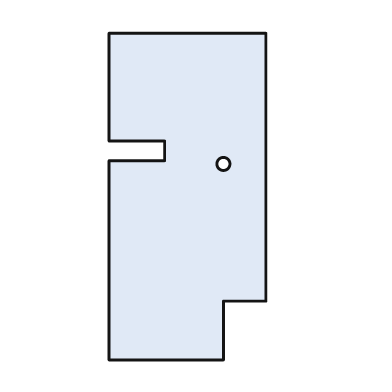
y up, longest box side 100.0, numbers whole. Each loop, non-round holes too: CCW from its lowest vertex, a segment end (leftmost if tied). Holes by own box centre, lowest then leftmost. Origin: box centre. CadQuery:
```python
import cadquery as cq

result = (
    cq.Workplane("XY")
    .moveTo(-24.0, -50.0)
    .lineTo(11.0, -50.0)
    .lineTo(11.0, -32.0)
    .lineTo(24.0, -32.0)
    .lineTo(24.0, 50.0)
    .lineTo(-24.0, 50.0)
    .lineTo(-24.0, 17.0)
    .lineTo(-7.0, 17.0)
    .lineTo(-7.0, 11.0)
    .lineTo(-24.0, 11.0)
    .close()
    .moveTo(11.0, 10.0)
    .circle(2.0)
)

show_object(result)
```